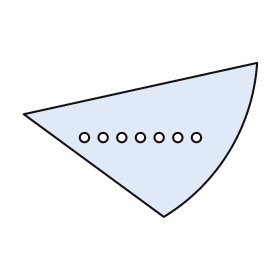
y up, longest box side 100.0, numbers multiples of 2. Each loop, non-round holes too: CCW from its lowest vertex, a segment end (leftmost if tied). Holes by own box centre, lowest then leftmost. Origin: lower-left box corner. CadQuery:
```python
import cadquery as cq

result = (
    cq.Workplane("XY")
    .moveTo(60.0, 0.0)
    .threePointArc((88.0, 28.0), (100.0, 66.0))
    .lineTo(0.0, 44.0)
    .close()
    .moveTo(26.0, 34.0)
    .circle(2.0)
    .moveTo(34.0, 34.0)
    .circle(2.0)
    .moveTo(42.0, 34.0)
    .circle(2.0)
    .moveTo(50.0, 34.0)
    .circle(2.0)
    .moveTo(58.0, 34.0)
    .circle(2.0)
    .moveTo(66.0, 34.0)
    .circle(2.0)
    .moveTo(74.0, 34.0)
    .circle(2.0)
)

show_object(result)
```